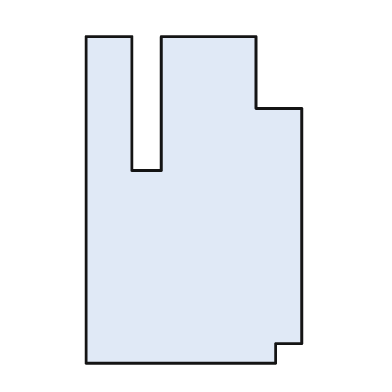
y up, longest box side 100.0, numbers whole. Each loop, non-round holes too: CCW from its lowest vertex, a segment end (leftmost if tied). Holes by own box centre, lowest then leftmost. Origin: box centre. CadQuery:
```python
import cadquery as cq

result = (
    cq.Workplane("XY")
    .moveTo(-33.0, -50.0)
    .lineTo(25.0, -50.0)
    .lineTo(25.0, -44.0)
    .lineTo(33.0, -44.0)
    .lineTo(33.0, 28.0)
    .lineTo(19.0, 28.0)
    .lineTo(19.0, 50.0)
    .lineTo(-10.0, 50.0)
    .lineTo(-10.0, 9.0)
    .lineTo(-19.0, 9.0)
    .lineTo(-19.0, 50.0)
    .lineTo(-33.0, 50.0)
    .close()
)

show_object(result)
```